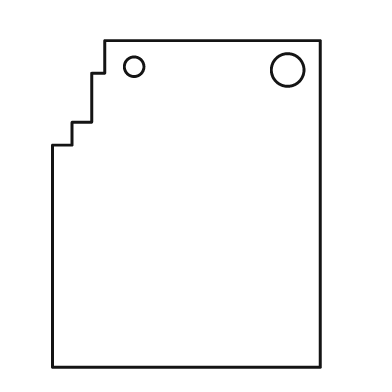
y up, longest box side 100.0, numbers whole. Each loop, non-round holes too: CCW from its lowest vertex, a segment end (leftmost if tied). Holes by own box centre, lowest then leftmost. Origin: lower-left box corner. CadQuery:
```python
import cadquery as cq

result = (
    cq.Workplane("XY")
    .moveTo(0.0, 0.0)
    .lineTo(82.0, 0.0)
    .lineTo(82.0, 100.0)
    .lineTo(16.0, 100.0)
    .lineTo(16.0, 90.0)
    .lineTo(12.0, 90.0)
    .lineTo(12.0, 75.0)
    .lineTo(6.0, 75.0)
    .lineTo(6.0, 68.0)
    .lineTo(0.0, 68.0)
    .close()
    .moveTo(72.0, 91.0)
    .circle(5.0)
    .moveTo(25.0, 92.0)
    .circle(3.0)
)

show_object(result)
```